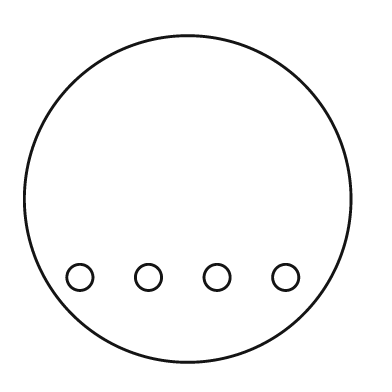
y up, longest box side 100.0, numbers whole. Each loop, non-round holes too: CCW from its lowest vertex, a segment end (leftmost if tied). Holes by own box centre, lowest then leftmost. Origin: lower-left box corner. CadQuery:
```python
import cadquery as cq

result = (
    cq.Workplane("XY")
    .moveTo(50.0, 50.0)
    .circle(50.0)
    .moveTo(17.0, 26.0)
    .circle(4.0)
    .moveTo(38.0, 26.0)
    .circle(4.0)
    .moveTo(59.0, 26.0)
    .circle(4.0)
    .moveTo(80.0, 26.0)
    .circle(4.0)
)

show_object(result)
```